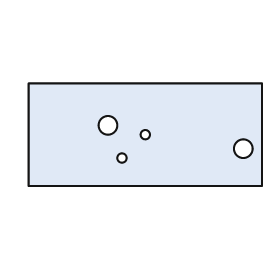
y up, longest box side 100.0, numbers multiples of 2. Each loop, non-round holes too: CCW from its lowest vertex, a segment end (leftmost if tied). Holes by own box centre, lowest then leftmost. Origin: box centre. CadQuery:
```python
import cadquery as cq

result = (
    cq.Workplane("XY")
    .moveTo(-50.0, -22.0)
    .lineTo(50.0, -22.0)
    .lineTo(50.0, 22.0)
    .lineTo(-50.0, 22.0)
    .close()
    .moveTo(-10.0, -10.0)
    .circle(2.0)
    .moveTo(42.0, -6.0)
    .circle(4.0)
    .moveTo(0.0, 0.0)
    .circle(2.0)
    .moveTo(-16.0, 4.0)
    .circle(4.0)
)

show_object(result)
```